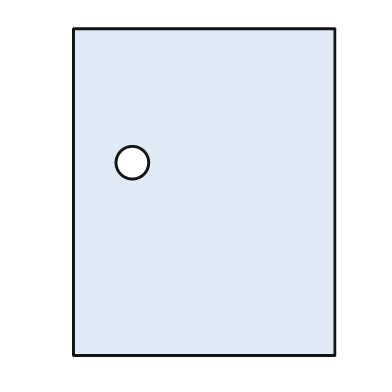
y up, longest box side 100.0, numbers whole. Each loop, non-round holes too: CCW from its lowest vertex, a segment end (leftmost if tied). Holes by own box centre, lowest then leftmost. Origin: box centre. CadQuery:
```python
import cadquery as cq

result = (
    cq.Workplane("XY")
    .moveTo(-40.0, -50.0)
    .lineTo(40.0, -50.0)
    .lineTo(40.0, 50.0)
    .lineTo(-40.0, 50.0)
    .close()
    .moveTo(-22.0, 9.0)
    .circle(5.0)
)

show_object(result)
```